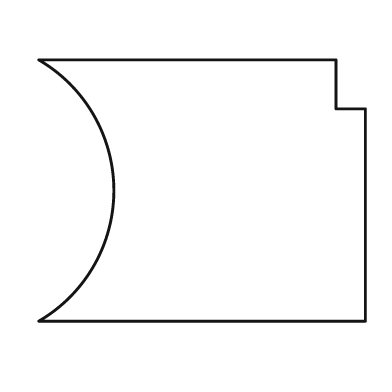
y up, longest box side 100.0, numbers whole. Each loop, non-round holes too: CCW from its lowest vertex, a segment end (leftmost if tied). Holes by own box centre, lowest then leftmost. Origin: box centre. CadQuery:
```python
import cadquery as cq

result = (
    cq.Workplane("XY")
    .moveTo(-50.0, -40.0)
    .lineTo(50.0, -40.0)
    .lineTo(50.0, 25.0)
    .lineTo(41.0, 25.0)
    .lineTo(41.0, 40.0)
    .lineTo(-50.0, 40.0)
    .threePointArc((-27.0, 0.0), (-50.0, -40.0))
    .close()
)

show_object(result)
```